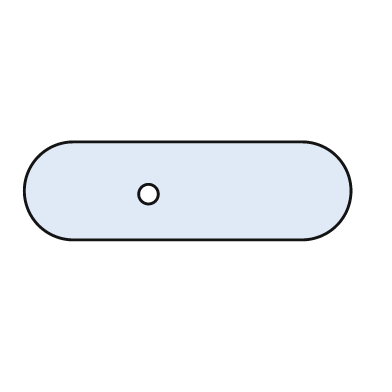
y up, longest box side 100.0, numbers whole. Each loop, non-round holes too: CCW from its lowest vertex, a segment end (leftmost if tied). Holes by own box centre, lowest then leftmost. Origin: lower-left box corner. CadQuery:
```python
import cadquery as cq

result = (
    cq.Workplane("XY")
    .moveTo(15.0, 0.0)
    .lineTo(85.0, 0.0)
    .threePointArc((100.0, 15.0), (85.0, 30.0))
    .lineTo(15.0, 30.0)
    .threePointArc((0.0, 15.0), (15.0, 0.0))
    .close()
    .moveTo(38.0, 14.0)
    .circle(3.0)
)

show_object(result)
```